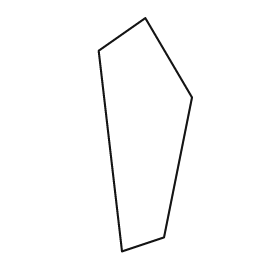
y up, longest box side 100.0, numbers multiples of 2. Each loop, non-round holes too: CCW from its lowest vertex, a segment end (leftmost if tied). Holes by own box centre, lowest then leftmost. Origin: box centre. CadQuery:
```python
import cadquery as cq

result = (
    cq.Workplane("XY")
    .moveTo(-10.0, -50.0)
    .lineTo(8.0, -44.0)
    .lineTo(20.0, 16.0)
    .lineTo(0.0, 50.0)
    .lineTo(-20.0, 36.0)
    .close()
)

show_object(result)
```